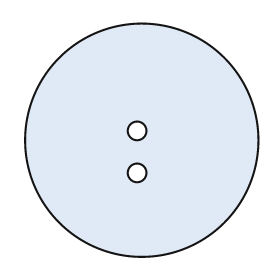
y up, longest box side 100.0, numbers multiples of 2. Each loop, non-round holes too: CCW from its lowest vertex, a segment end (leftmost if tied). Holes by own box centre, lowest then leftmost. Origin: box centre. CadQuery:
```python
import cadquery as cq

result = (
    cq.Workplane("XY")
    .moveTo(0.0, 0.0)
    .circle(50.0)
    .moveTo(-2.0, -14.0)
    .circle(4.0)
    .moveTo(-2.0, 4.0)
    .circle(4.0)
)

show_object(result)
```